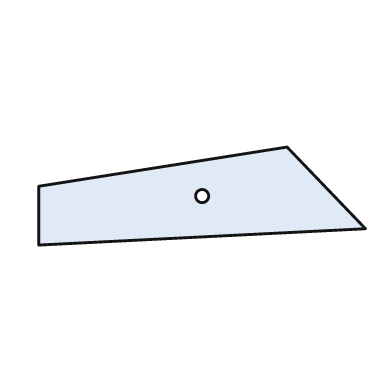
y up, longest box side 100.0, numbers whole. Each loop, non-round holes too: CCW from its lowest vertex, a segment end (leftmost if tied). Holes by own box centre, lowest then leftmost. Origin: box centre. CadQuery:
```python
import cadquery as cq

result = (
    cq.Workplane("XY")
    .moveTo(-50.0, -15.0)
    .lineTo(50.0, -10.0)
    .lineTo(26.0, 15.0)
    .lineTo(-50.0, 3.0)
    .close()
    .moveTo(0.0, 0.0)
    .circle(2.0)
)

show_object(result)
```